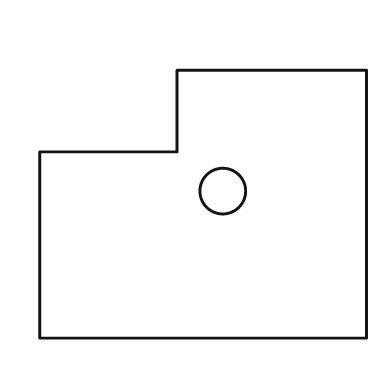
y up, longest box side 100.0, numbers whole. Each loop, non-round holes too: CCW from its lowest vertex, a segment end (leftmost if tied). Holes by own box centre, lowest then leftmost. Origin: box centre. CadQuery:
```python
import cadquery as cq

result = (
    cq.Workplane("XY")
    .moveTo(-50.0, -41.0)
    .lineTo(50.0, -41.0)
    .lineTo(50.0, 41.0)
    .lineTo(-8.0, 41.0)
    .lineTo(-8.0, 16.0)
    .lineTo(-50.0, 16.0)
    .close()
    .moveTo(6.0, 4.0)
    .circle(7.0)
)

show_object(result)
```